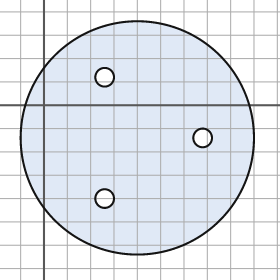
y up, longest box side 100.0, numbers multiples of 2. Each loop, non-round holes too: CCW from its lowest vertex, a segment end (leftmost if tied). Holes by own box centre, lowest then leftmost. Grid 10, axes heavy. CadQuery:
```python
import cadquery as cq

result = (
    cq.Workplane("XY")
    .moveTo(40.0, -14.0)
    .circle(50.0)
    .moveTo(26.0, -40.0)
    .circle(4.0)
    .moveTo(68.0, -14.0)
    .circle(4.0)
    .moveTo(26.0, 12.0)
    .circle(4.0)
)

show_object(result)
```